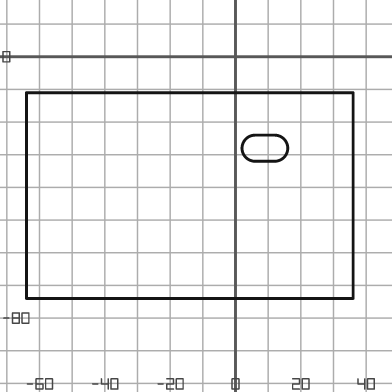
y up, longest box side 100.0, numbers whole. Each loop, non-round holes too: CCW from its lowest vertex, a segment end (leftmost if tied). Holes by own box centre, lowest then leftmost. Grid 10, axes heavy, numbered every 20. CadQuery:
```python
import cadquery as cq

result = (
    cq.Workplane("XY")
    .moveTo(-64.0, -74.0)
    .lineTo(36.0, -74.0)
    .lineTo(36.0, -11.0)
    .lineTo(-64.0, -11.0)
    .close()
    .moveTo(6.0, -32.0)
    .lineTo(12.0, -32.0)
    .threePointArc((16.0, -28.0), (12.0, -24.0))
    .lineTo(6.0, -24.0)
    .threePointArc((2.0, -28.0), (6.0, -32.0))
    .close()
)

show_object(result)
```